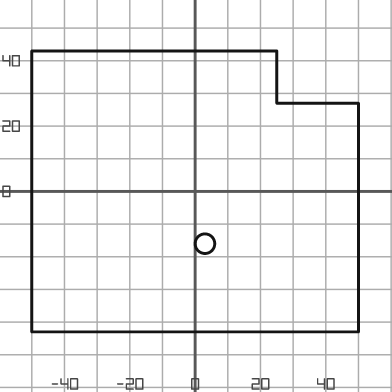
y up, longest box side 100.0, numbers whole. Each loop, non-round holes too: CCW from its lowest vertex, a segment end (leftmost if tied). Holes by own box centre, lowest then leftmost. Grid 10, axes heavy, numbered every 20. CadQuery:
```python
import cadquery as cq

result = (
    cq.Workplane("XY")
    .moveTo(-50.0, -43.0)
    .lineTo(50.0, -43.0)
    .lineTo(50.0, 27.0)
    .lineTo(25.0, 27.0)
    .lineTo(25.0, 43.0)
    .lineTo(-50.0, 43.0)
    .close()
    .moveTo(3.0, -16.0)
    .circle(3.0)
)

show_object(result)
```